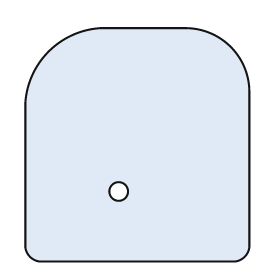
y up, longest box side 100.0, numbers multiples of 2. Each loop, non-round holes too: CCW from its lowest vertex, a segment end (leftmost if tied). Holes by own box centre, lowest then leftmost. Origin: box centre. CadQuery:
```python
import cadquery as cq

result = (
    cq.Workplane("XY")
    .moveTo(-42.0, -50.0)
    .lineTo(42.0, -50.0)
    .threePointArc((46.0, -48.0), (48.0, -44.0))
    .lineTo(48.0, 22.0)
    .threePointArc((40.0, 42.0), (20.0, 50.0))
    .lineTo(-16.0, 50.0)
    .threePointArc((-38.0, 40.0), (-48.0, 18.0))
    .lineTo(-48.0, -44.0)
    .threePointArc((-46.0, -48.0), (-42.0, -50.0))
    .close()
    .moveTo(-8.0, -20.0)
    .circle(4.0)
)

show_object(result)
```